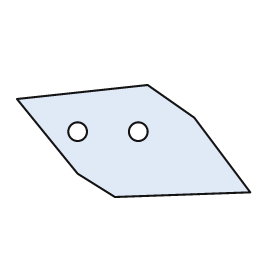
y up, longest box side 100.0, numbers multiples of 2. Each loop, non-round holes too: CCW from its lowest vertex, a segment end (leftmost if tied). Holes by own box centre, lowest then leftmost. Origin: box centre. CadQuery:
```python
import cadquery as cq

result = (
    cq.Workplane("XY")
    .moveTo(-8.0, -24.0)
    .lineTo(50.0, -22.0)
    .lineTo(26.0, 10.0)
    .lineTo(6.0, 24.0)
    .lineTo(-50.0, 18.0)
    .lineTo(-24.0, -14.0)
    .close()
    .moveTo(-24.0, 4.0)
    .circle(4.0)
    .moveTo(2.0, 4.0)
    .circle(4.0)
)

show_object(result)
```